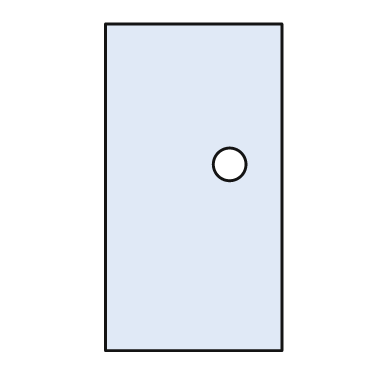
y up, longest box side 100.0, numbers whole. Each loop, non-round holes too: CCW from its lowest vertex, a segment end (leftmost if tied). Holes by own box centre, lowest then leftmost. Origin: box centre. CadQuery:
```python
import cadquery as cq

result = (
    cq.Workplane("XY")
    .moveTo(-27.0, -50.0)
    .lineTo(27.0, -50.0)
    .lineTo(27.0, 50.0)
    .lineTo(-27.0, 50.0)
    .close()
    .moveTo(11.0, 7.0)
    .circle(5.0)
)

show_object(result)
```